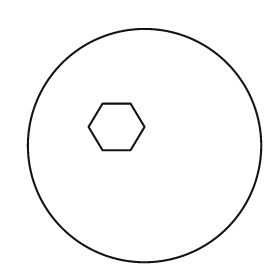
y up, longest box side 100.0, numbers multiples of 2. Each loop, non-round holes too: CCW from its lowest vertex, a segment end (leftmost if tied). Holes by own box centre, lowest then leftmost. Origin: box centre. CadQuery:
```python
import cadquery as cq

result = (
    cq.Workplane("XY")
    .moveTo(0.0, 0.0)
    .circle(50.0)
    .moveTo(-18.0, -2.0)
    .lineTo(-6.0, -2.0)
    .lineTo(0.0, 8.0)
    .lineTo(-6.0, 18.0)
    .lineTo(-18.0, 18.0)
    .lineTo(-24.0, 8.0)
    .close()
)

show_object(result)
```